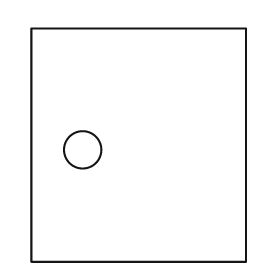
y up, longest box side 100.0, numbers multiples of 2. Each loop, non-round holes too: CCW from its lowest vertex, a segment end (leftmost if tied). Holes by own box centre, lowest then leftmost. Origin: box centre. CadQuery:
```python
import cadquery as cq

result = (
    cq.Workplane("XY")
    .moveTo(-46.0, -50.0)
    .lineTo(46.0, -50.0)
    .lineTo(46.0, 50.0)
    .lineTo(-46.0, 50.0)
    .close()
    .moveTo(-24.0, -2.0)
    .circle(8.0)
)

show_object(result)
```